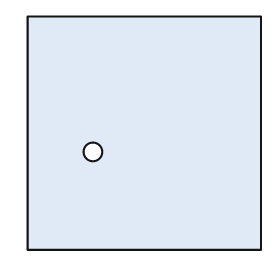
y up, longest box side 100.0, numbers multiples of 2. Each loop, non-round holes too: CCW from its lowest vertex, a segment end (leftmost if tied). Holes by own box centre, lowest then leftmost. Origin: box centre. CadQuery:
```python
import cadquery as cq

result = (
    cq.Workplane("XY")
    .moveTo(-50.0, -50.0)
    .lineTo(50.0, -50.0)
    .lineTo(50.0, 50.0)
    .lineTo(-50.0, 50.0)
    .close()
    .moveTo(-22.0, -8.0)
    .circle(4.0)
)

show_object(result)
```